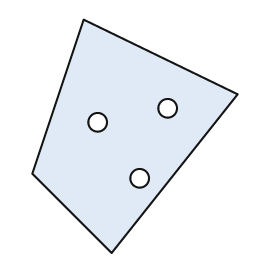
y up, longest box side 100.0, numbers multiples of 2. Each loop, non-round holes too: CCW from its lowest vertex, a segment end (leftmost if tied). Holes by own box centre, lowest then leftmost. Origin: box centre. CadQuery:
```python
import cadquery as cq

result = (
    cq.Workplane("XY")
    .moveTo(-10.0, -50.0)
    .lineTo(44.0, 18.0)
    .lineTo(-22.0, 50.0)
    .lineTo(-44.0, -16.0)
    .close()
    .moveTo(2.0, -18.0)
    .circle(4.0)
    .moveTo(-16.0, 6.0)
    .circle(4.0)
    .moveTo(14.0, 12.0)
    .circle(4.0)
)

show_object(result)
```